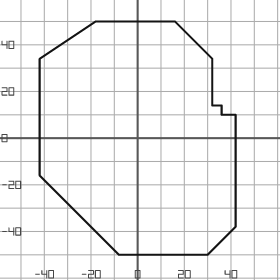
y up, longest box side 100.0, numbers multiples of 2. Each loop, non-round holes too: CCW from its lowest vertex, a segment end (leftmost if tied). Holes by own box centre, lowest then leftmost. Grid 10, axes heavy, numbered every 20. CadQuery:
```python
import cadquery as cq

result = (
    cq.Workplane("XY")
    .moveTo(-8.0, -50.0)
    .lineTo(30.0, -50.0)
    .lineTo(42.0, -38.0)
    .lineTo(42.0, 10.0)
    .lineTo(36.0, 10.0)
    .lineTo(36.0, 14.0)
    .lineTo(32.0, 14.0)
    .lineTo(32.0, 34.0)
    .lineTo(16.0, 50.0)
    .lineTo(-18.0, 50.0)
    .lineTo(-42.0, 34.0)
    .lineTo(-42.0, -16.0)
    .close()
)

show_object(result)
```